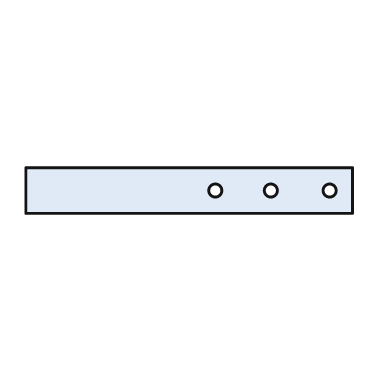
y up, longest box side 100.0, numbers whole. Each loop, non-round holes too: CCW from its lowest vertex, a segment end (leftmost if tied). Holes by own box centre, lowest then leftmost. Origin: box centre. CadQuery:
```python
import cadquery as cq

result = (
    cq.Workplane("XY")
    .moveTo(-50.0, -7.0)
    .lineTo(50.0, -7.0)
    .lineTo(50.0, 7.0)
    .lineTo(-50.0, 7.0)
    .close()
    .moveTo(8.0, 0.0)
    .circle(2.0)
    .moveTo(25.0, 0.0)
    .circle(2.0)
    .moveTo(43.0, 0.0)
    .circle(2.0)
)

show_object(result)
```